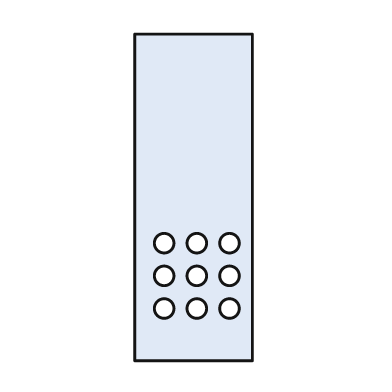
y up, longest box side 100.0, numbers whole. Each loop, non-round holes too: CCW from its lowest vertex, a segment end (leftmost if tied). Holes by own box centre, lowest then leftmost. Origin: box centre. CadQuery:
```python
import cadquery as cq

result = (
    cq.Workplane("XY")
    .moveTo(-18.0, -50.0)
    .lineTo(18.0, -50.0)
    .lineTo(18.0, 50.0)
    .lineTo(-18.0, 50.0)
    .close()
    .moveTo(-9.0, -34.0)
    .circle(3.0)
    .moveTo(1.0, -34.0)
    .circle(3.0)
    .moveTo(11.0, -34.0)
    .circle(3.0)
    .moveTo(-9.0, -24.0)
    .circle(3.0)
    .moveTo(1.0, -24.0)
    .circle(3.0)
    .moveTo(11.0, -24.0)
    .circle(3.0)
    .moveTo(-9.0, -14.0)
    .circle(3.0)
    .moveTo(1.0, -14.0)
    .circle(3.0)
    .moveTo(11.0, -14.0)
    .circle(3.0)
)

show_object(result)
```